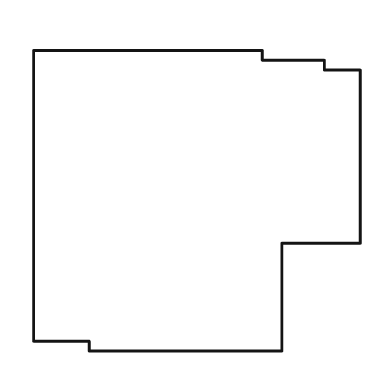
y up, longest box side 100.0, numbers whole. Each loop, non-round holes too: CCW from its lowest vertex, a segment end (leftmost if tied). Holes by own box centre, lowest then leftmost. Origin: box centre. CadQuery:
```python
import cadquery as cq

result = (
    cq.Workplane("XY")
    .moveTo(-33.0, -46.0)
    .lineTo(26.0, -46.0)
    .lineTo(26.0, -13.0)
    .lineTo(50.0, -13.0)
    .lineTo(50.0, 40.0)
    .lineTo(39.0, 40.0)
    .lineTo(39.0, 43.0)
    .lineTo(20.0, 43.0)
    .lineTo(20.0, 46.0)
    .lineTo(-50.0, 46.0)
    .lineTo(-50.0, -43.0)
    .lineTo(-33.0, -43.0)
    .close()
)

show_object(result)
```